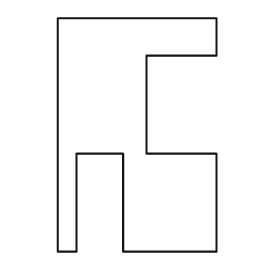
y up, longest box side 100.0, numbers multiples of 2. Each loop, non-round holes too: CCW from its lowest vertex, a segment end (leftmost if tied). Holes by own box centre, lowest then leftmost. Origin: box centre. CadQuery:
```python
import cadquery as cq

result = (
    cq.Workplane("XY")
    .moveTo(-34.0, -50.0)
    .lineTo(-26.0, -50.0)
    .lineTo(-26.0, -8.0)
    .lineTo(-6.0, -8.0)
    .lineTo(-6.0, -50.0)
    .lineTo(34.0, -50.0)
    .lineTo(34.0, -8.0)
    .lineTo(4.0, -8.0)
    .lineTo(4.0, 34.0)
    .lineTo(34.0, 34.0)
    .lineTo(34.0, 50.0)
    .lineTo(-34.0, 50.0)
    .close()
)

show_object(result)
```